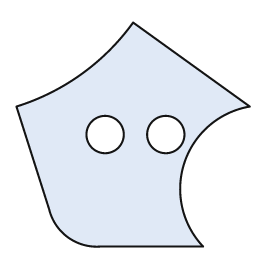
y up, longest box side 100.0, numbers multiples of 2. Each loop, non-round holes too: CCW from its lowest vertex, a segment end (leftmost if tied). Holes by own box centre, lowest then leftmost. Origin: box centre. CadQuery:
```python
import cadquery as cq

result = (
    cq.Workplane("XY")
    .moveTo(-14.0, -48.0)
    .lineTo(30.0, -48.0)
    .threePointArc((22.0, -12.0), (50.0, 12.0))
    .lineTo(0.0, 48.0)
    .threePointArc((-22.0, 26.0), (-50.0, 12.0))
    .lineTo(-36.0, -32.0)
    .threePointArc((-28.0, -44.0), (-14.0, -48.0))
    .close()
    .moveTo(-12.0, 0.0)
    .circle(8.0)
    .moveTo(14.0, 0.0)
    .circle(8.0)
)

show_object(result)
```